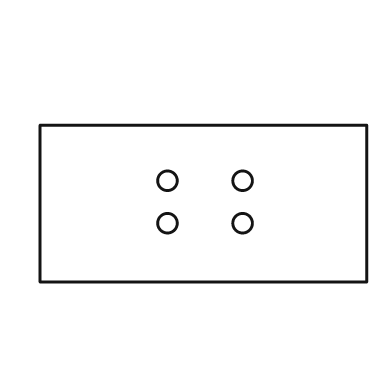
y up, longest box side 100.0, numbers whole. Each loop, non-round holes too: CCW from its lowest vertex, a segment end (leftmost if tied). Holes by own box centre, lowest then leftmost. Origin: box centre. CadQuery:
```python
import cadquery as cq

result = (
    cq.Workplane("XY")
    .moveTo(-50.0, -24.0)
    .lineTo(50.0, -24.0)
    .lineTo(50.0, 24.0)
    .lineTo(-50.0, 24.0)
    .close()
    .moveTo(-11.0, -6.0)
    .circle(3.0)
    .moveTo(12.0, -6.0)
    .circle(3.0)
    .moveTo(-11.0, 7.0)
    .circle(3.0)
    .moveTo(12.0, 7.0)
    .circle(3.0)
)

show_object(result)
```